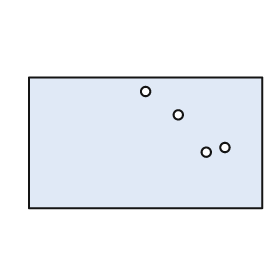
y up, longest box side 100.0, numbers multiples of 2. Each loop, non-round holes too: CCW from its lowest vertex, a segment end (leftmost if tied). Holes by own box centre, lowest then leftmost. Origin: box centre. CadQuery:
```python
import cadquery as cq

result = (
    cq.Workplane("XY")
    .moveTo(-50.0, -28.0)
    .lineTo(50.0, -28.0)
    .lineTo(50.0, 28.0)
    .lineTo(-50.0, 28.0)
    .close()
    .moveTo(26.0, -4.0)
    .circle(2.0)
    .moveTo(34.0, -2.0)
    .circle(2.0)
    .moveTo(14.0, 12.0)
    .circle(2.0)
    .moveTo(0.0, 22.0)
    .circle(2.0)
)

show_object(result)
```